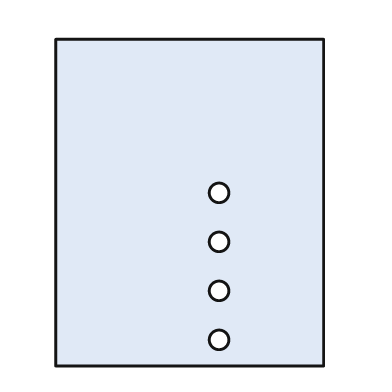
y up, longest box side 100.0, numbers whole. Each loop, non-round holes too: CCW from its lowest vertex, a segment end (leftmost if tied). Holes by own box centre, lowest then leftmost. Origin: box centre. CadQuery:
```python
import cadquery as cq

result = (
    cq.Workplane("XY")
    .moveTo(-41.0, -50.0)
    .lineTo(41.0, -50.0)
    .lineTo(41.0, 50.0)
    .lineTo(-41.0, 50.0)
    .close()
    .moveTo(9.0, -42.0)
    .circle(3.0)
    .moveTo(9.0, -27.0)
    .circle(3.0)
    .moveTo(9.0, -12.0)
    .circle(3.0)
    .moveTo(9.0, 3.0)
    .circle(3.0)
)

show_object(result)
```